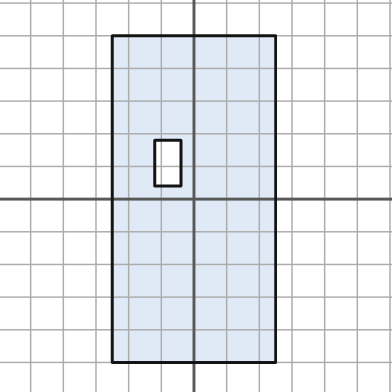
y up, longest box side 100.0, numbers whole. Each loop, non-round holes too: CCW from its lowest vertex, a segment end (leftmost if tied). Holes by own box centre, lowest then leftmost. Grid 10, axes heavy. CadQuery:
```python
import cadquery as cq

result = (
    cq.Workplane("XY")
    .moveTo(-25.0, -50.0)
    .lineTo(25.0, -50.0)
    .lineTo(25.0, 50.0)
    .lineTo(-25.0, 50.0)
    .close()
    .moveTo(-12.0, 4.0)
    .lineTo(-4.0, 4.0)
    .lineTo(-4.0, 18.0)
    .lineTo(-12.0, 18.0)
    .close()
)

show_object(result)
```